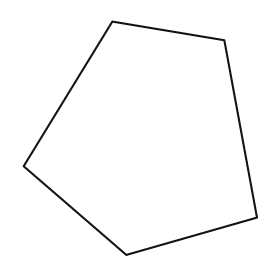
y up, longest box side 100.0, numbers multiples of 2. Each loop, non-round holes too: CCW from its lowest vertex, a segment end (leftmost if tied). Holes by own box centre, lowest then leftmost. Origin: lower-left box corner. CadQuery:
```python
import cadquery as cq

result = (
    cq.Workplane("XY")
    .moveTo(44.0, 0.0)
    .lineTo(100.0, 16.0)
    .lineTo(86.0, 92.0)
    .lineTo(38.0, 100.0)
    .lineTo(0.0, 38.0)
    .close()
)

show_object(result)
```